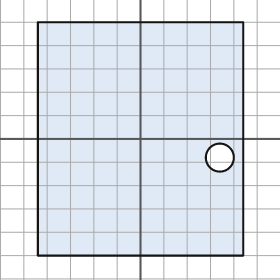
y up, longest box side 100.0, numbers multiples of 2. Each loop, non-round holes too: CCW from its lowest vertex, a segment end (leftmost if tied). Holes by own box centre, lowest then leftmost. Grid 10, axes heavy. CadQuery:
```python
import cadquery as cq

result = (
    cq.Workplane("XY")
    .moveTo(-44.0, -50.0)
    .lineTo(44.0, -50.0)
    .lineTo(44.0, 50.0)
    .lineTo(-44.0, 50.0)
    .close()
    .moveTo(34.0, -8.0)
    .circle(6.0)
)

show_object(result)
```